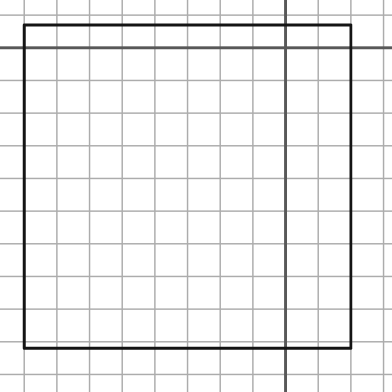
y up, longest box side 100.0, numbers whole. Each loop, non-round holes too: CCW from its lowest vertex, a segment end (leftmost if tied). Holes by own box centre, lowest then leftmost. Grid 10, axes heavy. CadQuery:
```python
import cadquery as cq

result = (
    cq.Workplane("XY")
    .moveTo(-80.0, -92.0)
    .lineTo(20.0, -92.0)
    .lineTo(20.0, 7.0)
    .lineTo(-80.0, 7.0)
    .close()
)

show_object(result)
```